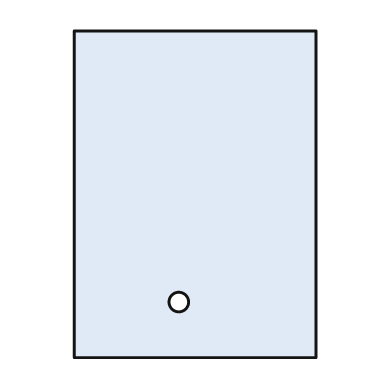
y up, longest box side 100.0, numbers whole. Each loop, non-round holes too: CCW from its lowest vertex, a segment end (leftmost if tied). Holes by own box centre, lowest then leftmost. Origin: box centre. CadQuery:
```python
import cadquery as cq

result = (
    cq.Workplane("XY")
    .moveTo(-37.0, -50.0)
    .lineTo(37.0, -50.0)
    .lineTo(37.0, 50.0)
    .lineTo(-37.0, 50.0)
    .close()
    .moveTo(-5.0, -33.0)
    .circle(3.0)
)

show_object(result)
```